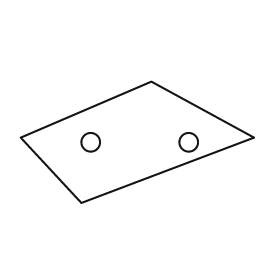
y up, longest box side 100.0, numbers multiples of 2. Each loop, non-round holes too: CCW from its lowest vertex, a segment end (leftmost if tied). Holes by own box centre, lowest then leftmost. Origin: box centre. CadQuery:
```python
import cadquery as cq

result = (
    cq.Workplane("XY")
    .moveTo(-24.0, -26.0)
    .lineTo(50.0, 2.0)
    .lineTo(6.0, 26.0)
    .lineTo(-50.0, 2.0)
    .close()
    .moveTo(-20.0, 0.0)
    .circle(4.0)
    .moveTo(22.0, 0.0)
    .circle(4.0)
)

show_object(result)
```